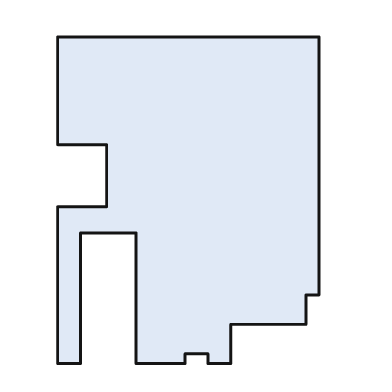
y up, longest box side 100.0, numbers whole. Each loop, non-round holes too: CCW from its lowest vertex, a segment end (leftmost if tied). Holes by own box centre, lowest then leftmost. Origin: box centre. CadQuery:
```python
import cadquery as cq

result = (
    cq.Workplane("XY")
    .moveTo(-40.0, -50.0)
    .lineTo(-33.0, -50.0)
    .lineTo(-33.0, -10.0)
    .lineTo(-16.0, -10.0)
    .lineTo(-16.0, -50.0)
    .lineTo(-1.0, -50.0)
    .lineTo(-1.0, -47.0)
    .lineTo(6.0, -47.0)
    .lineTo(6.0, -50.0)
    .lineTo(13.0, -50.0)
    .lineTo(13.0, -38.0)
    .lineTo(36.0, -38.0)
    .lineTo(36.0, -29.0)
    .lineTo(40.0, -29.0)
    .lineTo(40.0, 50.0)
    .lineTo(-40.0, 50.0)
    .lineTo(-40.0, 17.0)
    .lineTo(-25.0, 17.0)
    .lineTo(-25.0, -2.0)
    .lineTo(-40.0, -2.0)
    .close()
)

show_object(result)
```